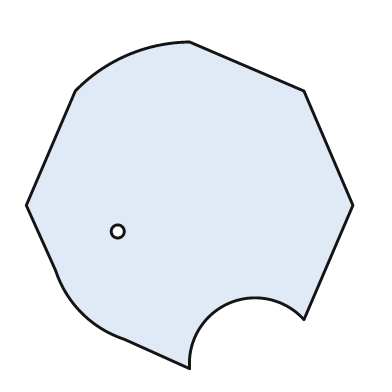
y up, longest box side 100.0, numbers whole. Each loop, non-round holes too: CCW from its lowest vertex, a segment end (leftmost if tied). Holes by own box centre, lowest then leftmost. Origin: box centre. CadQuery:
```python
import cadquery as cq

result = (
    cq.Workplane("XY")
    .moveTo(0.0, -50.0)
    .threePointArc((12.0, -30.0), (35.0, -35.0))
    .lineTo(50.0, 0.0)
    .lineTo(35.0, 35.0)
    .lineTo(0.0, 50.0)
    .threePointArc((-19.0, 46.0), (-35.0, 35.0))
    .lineTo(-50.0, 0.0)
    .lineTo(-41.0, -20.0)
    .threePointArc((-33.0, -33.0), (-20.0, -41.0))
    .close()
    .moveTo(-22.0, -8.0)
    .circle(2.0)
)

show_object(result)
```